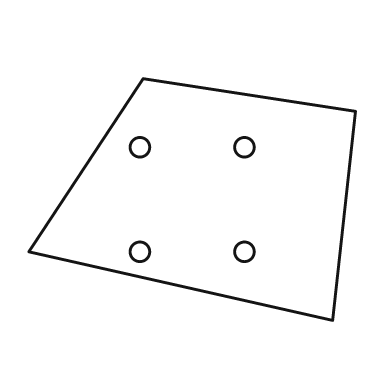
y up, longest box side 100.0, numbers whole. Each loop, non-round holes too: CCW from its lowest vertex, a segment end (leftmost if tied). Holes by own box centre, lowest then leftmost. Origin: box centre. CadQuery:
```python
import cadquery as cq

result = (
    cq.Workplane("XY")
    .moveTo(43.0, -37.0)
    .lineTo(50.0, 27.0)
    .lineTo(-15.0, 37.0)
    .lineTo(-50.0, -16.0)
    .close()
    .moveTo(-16.0, -16.0)
    .circle(3.0)
    .moveTo(16.0, -16.0)
    .circle(3.0)
    .moveTo(-16.0, 16.0)
    .circle(3.0)
    .moveTo(16.0, 16.0)
    .circle(3.0)
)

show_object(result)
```